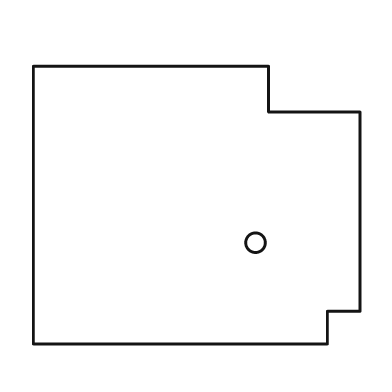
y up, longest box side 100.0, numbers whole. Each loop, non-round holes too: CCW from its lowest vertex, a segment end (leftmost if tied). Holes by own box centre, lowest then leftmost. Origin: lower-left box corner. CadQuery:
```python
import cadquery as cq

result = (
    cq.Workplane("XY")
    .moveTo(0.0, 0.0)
    .lineTo(90.0, 0.0)
    .lineTo(90.0, 10.0)
    .lineTo(100.0, 10.0)
    .lineTo(100.0, 71.0)
    .lineTo(72.0, 71.0)
    .lineTo(72.0, 85.0)
    .lineTo(0.0, 85.0)
    .close()
    .moveTo(68.0, 31.0)
    .circle(3.0)
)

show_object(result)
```